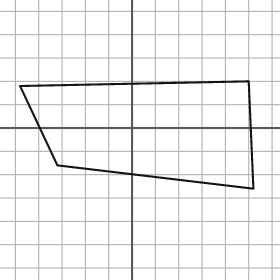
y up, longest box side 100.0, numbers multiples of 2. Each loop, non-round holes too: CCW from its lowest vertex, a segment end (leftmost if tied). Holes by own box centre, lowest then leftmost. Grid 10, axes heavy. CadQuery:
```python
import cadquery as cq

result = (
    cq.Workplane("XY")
    .moveTo(52.0, -26.0)
    .lineTo(50.0, 20.0)
    .lineTo(-48.0, 18.0)
    .lineTo(-32.0, -16.0)
    .close()
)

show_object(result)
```